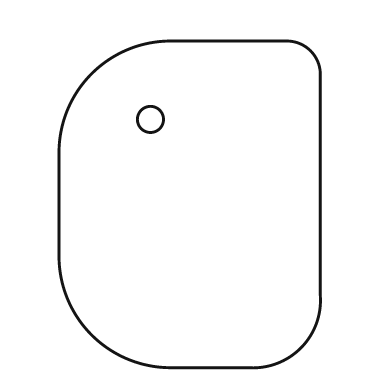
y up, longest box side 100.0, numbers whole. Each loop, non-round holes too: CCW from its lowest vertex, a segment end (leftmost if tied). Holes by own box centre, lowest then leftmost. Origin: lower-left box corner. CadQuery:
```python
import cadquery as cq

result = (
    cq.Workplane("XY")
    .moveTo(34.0, 0.0)
    .lineTo(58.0, 0.0)
    .threePointArc((74.0, 6.0), (80.0, 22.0))
    .lineTo(80.0, 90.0)
    .threePointArc((77.0, 97.0), (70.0, 100.0))
    .lineTo(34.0, 100.0)
    .threePointArc((10.0, 90.0), (0.0, 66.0))
    .lineTo(0.0, 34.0)
    .threePointArc((10.0, 10.0), (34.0, 0.0))
    .close()
    .moveTo(28.0, 76.0)
    .circle(4.0)
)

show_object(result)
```